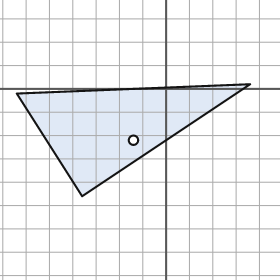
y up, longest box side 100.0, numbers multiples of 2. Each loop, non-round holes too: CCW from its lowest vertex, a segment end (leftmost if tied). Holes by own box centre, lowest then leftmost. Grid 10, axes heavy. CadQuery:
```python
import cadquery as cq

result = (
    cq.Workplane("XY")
    .moveTo(-36.0, -46.0)
    .lineTo(36.0, 2.0)
    .lineTo(-64.0, -2.0)
    .close()
    .moveTo(-14.0, -22.0)
    .circle(2.0)
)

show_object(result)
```